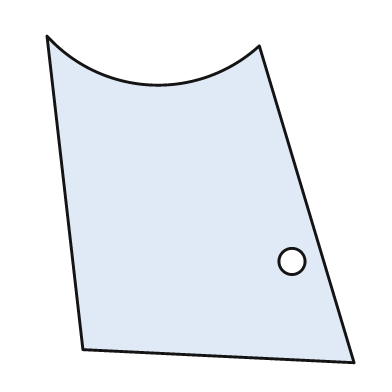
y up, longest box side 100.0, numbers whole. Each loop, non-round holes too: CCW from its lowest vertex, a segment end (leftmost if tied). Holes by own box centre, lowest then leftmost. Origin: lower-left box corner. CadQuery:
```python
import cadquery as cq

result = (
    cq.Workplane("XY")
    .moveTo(94.0, 0.0)
    .lineTo(65.0, 97.0)
    .threePointArc((32.0, 85.0), (0.0, 100.0))
    .lineTo(11.0, 4.0)
    .close()
    .moveTo(75.0, 31.0)
    .circle(4.0)
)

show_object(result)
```